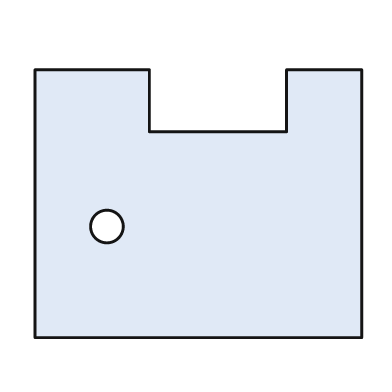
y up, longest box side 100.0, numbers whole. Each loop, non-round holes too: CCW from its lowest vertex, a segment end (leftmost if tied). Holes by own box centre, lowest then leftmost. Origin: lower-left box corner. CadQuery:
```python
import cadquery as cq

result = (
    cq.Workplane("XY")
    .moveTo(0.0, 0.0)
    .lineTo(100.0, 0.0)
    .lineTo(100.0, 82.0)
    .lineTo(77.0, 82.0)
    .lineTo(77.0, 63.0)
    .lineTo(35.0, 63.0)
    .lineTo(35.0, 82.0)
    .lineTo(0.0, 82.0)
    .close()
    .moveTo(22.0, 34.0)
    .circle(5.0)
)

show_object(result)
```